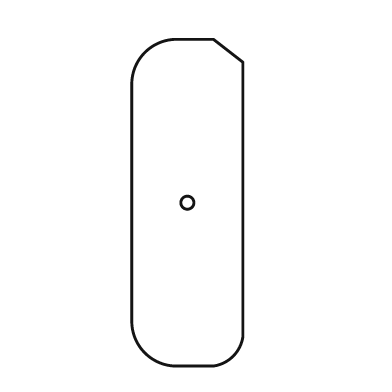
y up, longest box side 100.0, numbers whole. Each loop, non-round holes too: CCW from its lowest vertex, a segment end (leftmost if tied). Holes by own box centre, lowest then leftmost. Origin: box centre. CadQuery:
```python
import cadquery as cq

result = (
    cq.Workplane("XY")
    .moveTo(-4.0, -50.0)
    .lineTo(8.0, -50.0)
    .threePointArc((14.0, -47.0), (17.0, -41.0))
    .lineTo(17.0, 43.0)
    .lineTo(8.0, 50.0)
    .lineTo(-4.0, 50.0)
    .threePointArc((-13.0, 46.0), (-17.0, 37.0))
    .lineTo(-17.0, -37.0)
    .threePointArc((-13.0, -46.0), (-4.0, -50.0))
    .close()
    .moveTo(0.0, 0.0)
    .circle(2.0)
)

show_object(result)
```